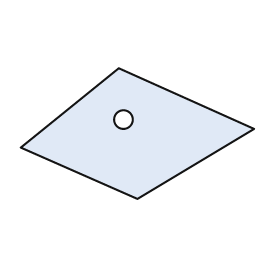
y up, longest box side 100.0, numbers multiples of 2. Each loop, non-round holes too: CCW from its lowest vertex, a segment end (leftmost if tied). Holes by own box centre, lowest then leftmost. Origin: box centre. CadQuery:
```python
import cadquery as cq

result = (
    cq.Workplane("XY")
    .moveTo(0.0, -28.0)
    .lineTo(50.0, 2.0)
    .lineTo(-8.0, 28.0)
    .lineTo(-50.0, -6.0)
    .close()
    .moveTo(-6.0, 6.0)
    .circle(4.0)
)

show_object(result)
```